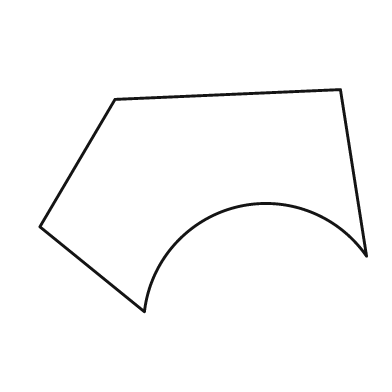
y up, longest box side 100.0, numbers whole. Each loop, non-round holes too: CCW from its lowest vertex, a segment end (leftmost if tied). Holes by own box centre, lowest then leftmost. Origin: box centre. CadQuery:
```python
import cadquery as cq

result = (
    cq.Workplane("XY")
    .moveTo(-18.0, -34.0)
    .threePointArc((10.0, -2.0), (50.0, -17.0))
    .lineTo(42.0, 34.0)
    .lineTo(-27.0, 31.0)
    .lineTo(-50.0, -8.0)
    .close()
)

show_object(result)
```